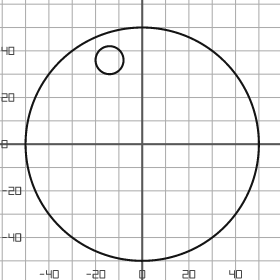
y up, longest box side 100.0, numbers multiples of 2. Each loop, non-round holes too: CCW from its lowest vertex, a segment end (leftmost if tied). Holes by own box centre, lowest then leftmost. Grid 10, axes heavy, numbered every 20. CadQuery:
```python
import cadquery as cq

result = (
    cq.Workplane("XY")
    .moveTo(0.0, 0.0)
    .circle(50.0)
    .moveTo(-14.0, 36.0)
    .circle(6.0)
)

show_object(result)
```